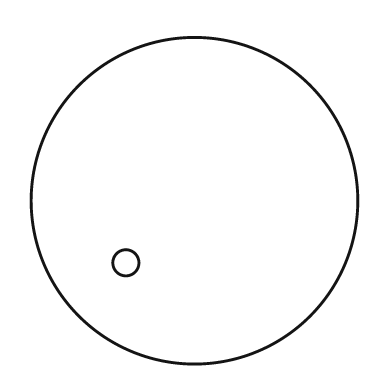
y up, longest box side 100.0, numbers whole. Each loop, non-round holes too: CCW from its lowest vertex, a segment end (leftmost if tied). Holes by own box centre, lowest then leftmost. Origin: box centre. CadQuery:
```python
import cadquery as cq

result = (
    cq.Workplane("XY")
    .moveTo(0.0, 0.0)
    .circle(50.0)
    .moveTo(-21.0, -19.0)
    .circle(4.0)
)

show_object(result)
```